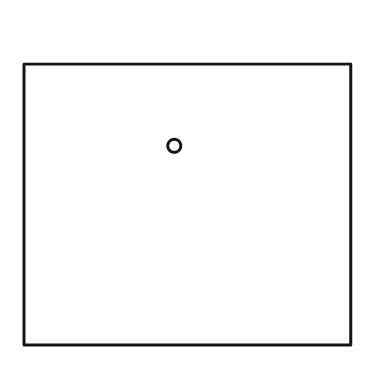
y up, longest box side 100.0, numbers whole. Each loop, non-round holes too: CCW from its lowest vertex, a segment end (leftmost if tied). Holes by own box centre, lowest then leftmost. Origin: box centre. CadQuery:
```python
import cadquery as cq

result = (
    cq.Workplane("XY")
    .moveTo(-50.0, -43.0)
    .lineTo(50.0, -43.0)
    .lineTo(50.0, 43.0)
    .lineTo(-50.0, 43.0)
    .close()
    .moveTo(-4.0, 18.0)
    .circle(2.0)
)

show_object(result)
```